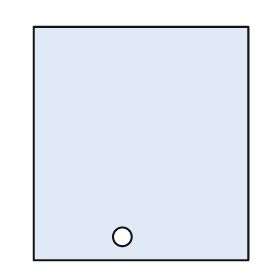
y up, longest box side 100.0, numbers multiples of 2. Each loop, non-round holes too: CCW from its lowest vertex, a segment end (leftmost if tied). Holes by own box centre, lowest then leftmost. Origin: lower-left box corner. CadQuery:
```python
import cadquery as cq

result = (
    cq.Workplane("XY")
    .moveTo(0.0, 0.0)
    .lineTo(92.0, 0.0)
    .lineTo(92.0, 100.0)
    .lineTo(0.0, 100.0)
    .close()
    .moveTo(38.0, 10.0)
    .circle(4.0)
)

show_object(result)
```